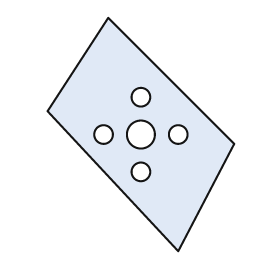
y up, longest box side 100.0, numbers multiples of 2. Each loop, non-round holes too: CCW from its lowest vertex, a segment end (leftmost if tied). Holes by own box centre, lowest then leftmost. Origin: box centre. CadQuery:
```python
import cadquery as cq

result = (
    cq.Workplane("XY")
    .moveTo(16.0, -50.0)
    .lineTo(40.0, -4.0)
    .lineTo(-14.0, 50.0)
    .lineTo(-40.0, 10.0)
    .close()
    .moveTo(0.0, -16.0)
    .circle(4.0)
    .moveTo(-16.0, 0.0)
    .circle(4.0)
    .moveTo(0.0, 0.0)
    .circle(6.0)
    .moveTo(16.0, 0.0)
    .circle(4.0)
    .moveTo(0.0, 16.0)
    .circle(4.0)
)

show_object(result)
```